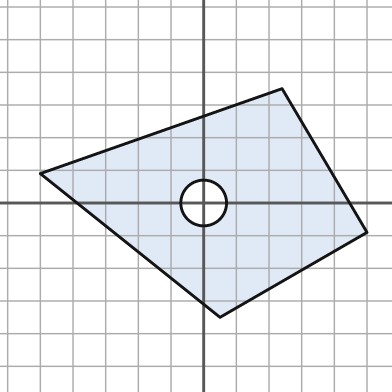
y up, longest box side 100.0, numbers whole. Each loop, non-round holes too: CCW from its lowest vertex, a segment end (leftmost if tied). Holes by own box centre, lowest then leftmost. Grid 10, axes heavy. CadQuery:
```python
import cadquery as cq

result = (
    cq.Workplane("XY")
    .moveTo(5.0, -35.0)
    .lineTo(50.0, -9.0)
    .lineTo(24.0, 35.0)
    .lineTo(-50.0, 9.0)
    .close()
    .moveTo(0.0, 0.0)
    .circle(7.0)
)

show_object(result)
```